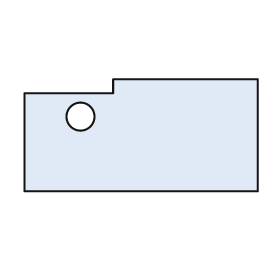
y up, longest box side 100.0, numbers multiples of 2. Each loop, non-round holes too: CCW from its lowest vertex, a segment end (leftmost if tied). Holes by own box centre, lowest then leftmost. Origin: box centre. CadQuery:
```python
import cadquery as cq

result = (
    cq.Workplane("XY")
    .moveTo(-50.0, -24.0)
    .lineTo(50.0, -24.0)
    .lineTo(50.0, 24.0)
    .lineTo(-12.0, 24.0)
    .lineTo(-12.0, 18.0)
    .lineTo(-50.0, 18.0)
    .close()
    .moveTo(-26.0, 8.0)
    .circle(6.0)
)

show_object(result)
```